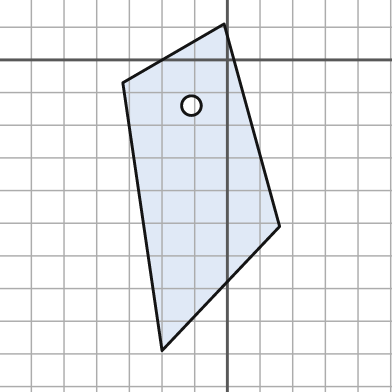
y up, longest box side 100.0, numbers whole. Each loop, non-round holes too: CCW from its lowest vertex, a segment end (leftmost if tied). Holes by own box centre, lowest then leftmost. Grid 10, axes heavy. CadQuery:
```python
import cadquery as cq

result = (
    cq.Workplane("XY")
    .moveTo(-20.0, -89.0)
    .lineTo(16.0, -51.0)
    .lineTo(-1.0, 11.0)
    .lineTo(-32.0, -7.0)
    .close()
    .moveTo(-11.0, -14.0)
    .circle(3.0)
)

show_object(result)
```